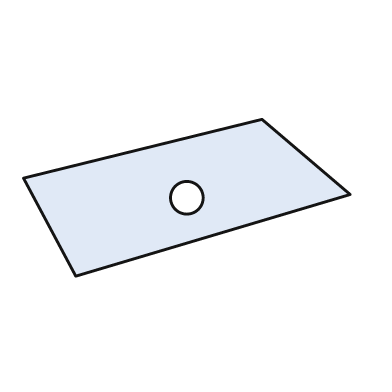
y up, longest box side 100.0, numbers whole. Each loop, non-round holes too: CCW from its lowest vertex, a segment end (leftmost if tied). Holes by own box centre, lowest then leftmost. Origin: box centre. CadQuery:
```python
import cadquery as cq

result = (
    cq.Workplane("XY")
    .moveTo(-34.0, -24.0)
    .lineTo(50.0, 1.0)
    .lineTo(23.0, 24.0)
    .lineTo(-50.0, 6.0)
    .close()
    .moveTo(0.0, 0.0)
    .circle(5.0)
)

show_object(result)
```